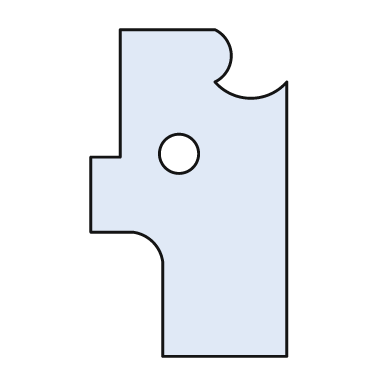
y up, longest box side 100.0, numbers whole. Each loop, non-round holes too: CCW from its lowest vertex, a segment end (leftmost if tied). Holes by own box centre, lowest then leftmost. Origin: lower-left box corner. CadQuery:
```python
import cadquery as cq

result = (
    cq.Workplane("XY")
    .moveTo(22.0, 0.0)
    .lineTo(60.0, 0.0)
    .lineTo(60.0, 84.0)
    .threePointArc((49.0, 79.0), (38.0, 84.0))
    .threePointArc((43.0, 92.0), (38.0, 100.0))
    .lineTo(9.0, 100.0)
    .lineTo(9.0, 61.0)
    .lineTo(0.0, 61.0)
    .lineTo(0.0, 38.0)
    .lineTo(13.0, 38.0)
    .threePointArc((19.0, 35.0), (22.0, 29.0))
    .close()
    .moveTo(27.0, 62.0)
    .circle(6.0)
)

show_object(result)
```